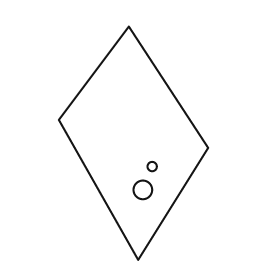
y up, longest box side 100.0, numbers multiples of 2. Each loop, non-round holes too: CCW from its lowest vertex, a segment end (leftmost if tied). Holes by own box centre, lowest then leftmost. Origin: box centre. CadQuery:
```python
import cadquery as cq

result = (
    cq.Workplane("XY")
    .moveTo(2.0, -50.0)
    .lineTo(32.0, -2.0)
    .lineTo(-2.0, 50.0)
    .lineTo(-32.0, 10.0)
    .close()
    .moveTo(4.0, -20.0)
    .circle(4.0)
    .moveTo(8.0, -10.0)
    .circle(2.0)
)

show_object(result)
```